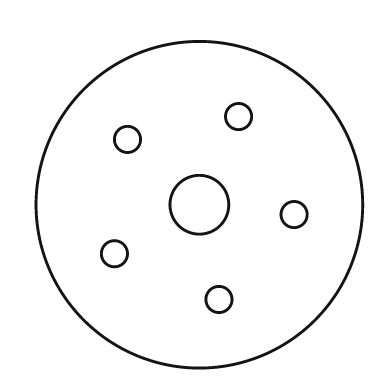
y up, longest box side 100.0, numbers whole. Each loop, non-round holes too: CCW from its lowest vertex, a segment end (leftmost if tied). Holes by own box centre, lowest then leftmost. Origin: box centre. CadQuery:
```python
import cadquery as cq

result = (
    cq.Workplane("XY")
    .moveTo(0.0, 0.0)
    .circle(50.0)
    .moveTo(6.0, -29.0)
    .circle(4.0)
    .moveTo(-26.0, -15.0)
    .circle(4.0)
    .moveTo(29.0, -3.0)
    .circle(4.0)
    .moveTo(0.0, 0.0)
    .circle(9.0)
    .moveTo(-22.0, 20.0)
    .circle(4.0)
    .moveTo(12.0, 27.0)
    .circle(4.0)
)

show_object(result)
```